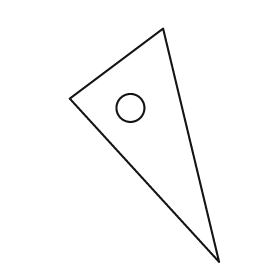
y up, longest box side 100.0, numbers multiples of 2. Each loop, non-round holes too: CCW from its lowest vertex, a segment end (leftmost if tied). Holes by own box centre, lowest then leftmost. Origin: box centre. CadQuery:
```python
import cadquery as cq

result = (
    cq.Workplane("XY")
    .moveTo(32.0, -50.0)
    .lineTo(8.0, 50.0)
    .lineTo(-32.0, 20.0)
    .close()
    .moveTo(-6.0, 16.0)
    .circle(6.0)
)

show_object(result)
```